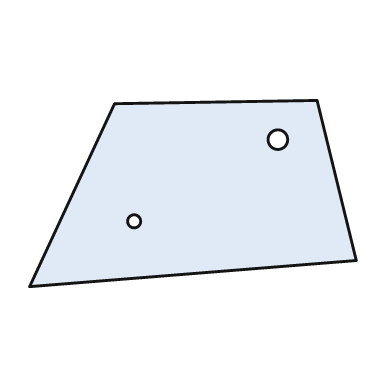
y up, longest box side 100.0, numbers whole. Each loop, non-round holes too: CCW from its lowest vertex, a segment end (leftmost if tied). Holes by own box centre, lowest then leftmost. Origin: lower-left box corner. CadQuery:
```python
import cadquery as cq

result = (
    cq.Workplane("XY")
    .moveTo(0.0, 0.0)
    .lineTo(100.0, 8.0)
    .lineTo(88.0, 57.0)
    .lineTo(26.0, 56.0)
    .close()
    .moveTo(32.0, 20.0)
    .circle(2.0)
    .moveTo(76.0, 45.0)
    .circle(3.0)
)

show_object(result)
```